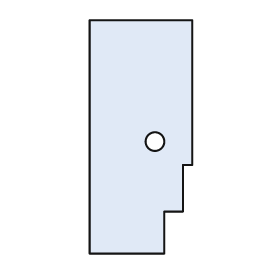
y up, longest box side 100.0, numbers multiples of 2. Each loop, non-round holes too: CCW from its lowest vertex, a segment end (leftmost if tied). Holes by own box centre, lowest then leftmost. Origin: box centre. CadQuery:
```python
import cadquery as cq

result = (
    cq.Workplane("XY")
    .moveTo(-22.0, -50.0)
    .lineTo(10.0, -50.0)
    .lineTo(10.0, -32.0)
    .lineTo(18.0, -32.0)
    .lineTo(18.0, -12.0)
    .lineTo(22.0, -12.0)
    .lineTo(22.0, 50.0)
    .lineTo(-22.0, 50.0)
    .close()
    .moveTo(6.0, -2.0)
    .circle(4.0)
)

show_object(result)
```